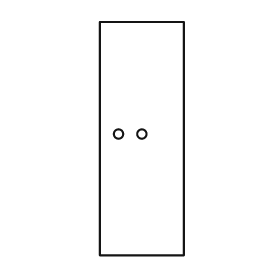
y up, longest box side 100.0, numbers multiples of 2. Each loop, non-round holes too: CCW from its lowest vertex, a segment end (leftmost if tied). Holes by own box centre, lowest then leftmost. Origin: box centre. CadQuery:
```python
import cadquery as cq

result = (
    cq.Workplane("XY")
    .moveTo(-18.0, -50.0)
    .lineTo(18.0, -50.0)
    .lineTo(18.0, 50.0)
    .lineTo(-18.0, 50.0)
    .close()
    .moveTo(-10.0, 2.0)
    .circle(2.0)
    .moveTo(0.0, 2.0)
    .circle(2.0)
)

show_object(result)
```